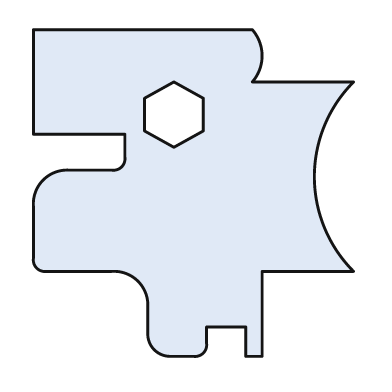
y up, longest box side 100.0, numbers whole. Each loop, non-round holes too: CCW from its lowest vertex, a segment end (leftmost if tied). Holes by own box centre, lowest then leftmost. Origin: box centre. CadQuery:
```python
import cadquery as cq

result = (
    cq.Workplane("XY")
    .moveTo(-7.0, -50.0)
    .lineTo(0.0, -50.0)
    .threePointArc((3.0, -49.0), (4.0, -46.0))
    .lineTo(4.0, -41.0)
    .lineTo(16.0, -41.0)
    .lineTo(16.0, -50.0)
    .lineTo(21.0, -50.0)
    .lineTo(21.0, -24.0)
    .lineTo(49.0, -24.0)
    .threePointArc((37.0, 5.0), (49.0, 34.0))
    .lineTo(18.0, 34.0)
    .threePointArc((21.0, 42.0), (18.0, 50.0))
    .lineTo(-49.0, 50.0)
    .lineTo(-49.0, 18.0)
    .lineTo(-21.0, 18.0)
    .lineTo(-21.0, 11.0)
    .threePointArc((-22.0, 8.0), (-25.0, 7.0))
    .lineTo(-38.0, 7.0)
    .threePointArc((-46.0, 4.0), (-49.0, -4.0))
    .lineTo(-49.0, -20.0)
    .threePointArc((-48.0, -23.0), (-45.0, -24.0))
    .lineTo(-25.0, -24.0)
    .threePointArc((-17.0, -27.0), (-14.0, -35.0))
    .lineTo(-14.0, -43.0)
    .threePointArc((-12.0, -48.0), (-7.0, -50.0))
    .close()
    .moveTo(-6.0, 14.0)
    .lineTo(3.0, 19.0)
    .lineTo(3.0, 29.0)
    .lineTo(-6.0, 34.0)
    .lineTo(-15.0, 29.0)
    .lineTo(-15.0, 19.0)
    .close()
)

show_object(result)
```